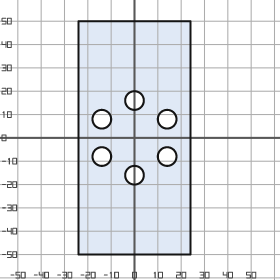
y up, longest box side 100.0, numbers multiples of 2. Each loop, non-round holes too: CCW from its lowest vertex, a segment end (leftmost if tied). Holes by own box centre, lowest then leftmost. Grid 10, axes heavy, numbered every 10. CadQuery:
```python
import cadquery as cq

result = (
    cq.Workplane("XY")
    .moveTo(-24.0, -50.0)
    .lineTo(24.0, -50.0)
    .lineTo(24.0, 50.0)
    .lineTo(-24.0, 50.0)
    .close()
    .moveTo(0.0, -16.0)
    .circle(4.0)
    .moveTo(-14.0, -8.0)
    .circle(4.0)
    .moveTo(14.0, -8.0)
    .circle(4.0)
    .moveTo(-14.0, 8.0)
    .circle(4.0)
    .moveTo(14.0, 8.0)
    .circle(4.0)
    .moveTo(0.0, 16.0)
    .circle(4.0)
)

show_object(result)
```